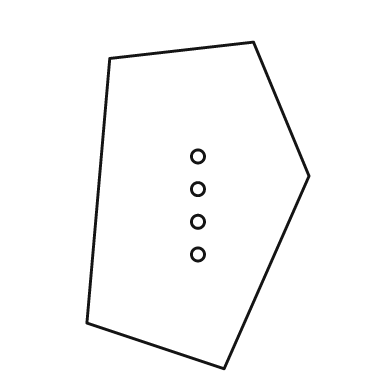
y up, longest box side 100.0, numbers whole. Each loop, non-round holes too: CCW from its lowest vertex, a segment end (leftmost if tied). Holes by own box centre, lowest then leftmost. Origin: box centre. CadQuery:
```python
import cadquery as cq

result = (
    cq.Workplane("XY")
    .moveTo(8.0, -50.0)
    .lineTo(34.0, 9.0)
    .lineTo(17.0, 50.0)
    .lineTo(-27.0, 45.0)
    .lineTo(-34.0, -36.0)
    .close()
    .moveTo(0.0, -15.0)
    .circle(2.0)
    .moveTo(0.0, -5.0)
    .circle(2.0)
    .moveTo(0.0, 5.0)
    .circle(2.0)
    .moveTo(0.0, 15.0)
    .circle(2.0)
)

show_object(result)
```